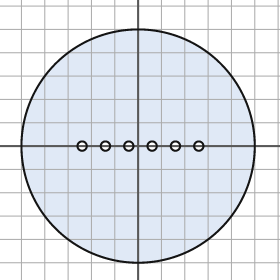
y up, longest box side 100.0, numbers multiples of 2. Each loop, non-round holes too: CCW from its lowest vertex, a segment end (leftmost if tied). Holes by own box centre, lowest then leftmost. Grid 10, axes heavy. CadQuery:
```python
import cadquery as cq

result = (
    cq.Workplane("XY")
    .moveTo(0.0, 0.0)
    .circle(50.0)
    .moveTo(-24.0, 0.0)
    .circle(2.0)
    .moveTo(-14.0, 0.0)
    .circle(2.0)
    .moveTo(-4.0, 0.0)
    .circle(2.0)
    .moveTo(6.0, 0.0)
    .circle(2.0)
    .moveTo(16.0, 0.0)
    .circle(2.0)
    .moveTo(26.0, 0.0)
    .circle(2.0)
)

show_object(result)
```